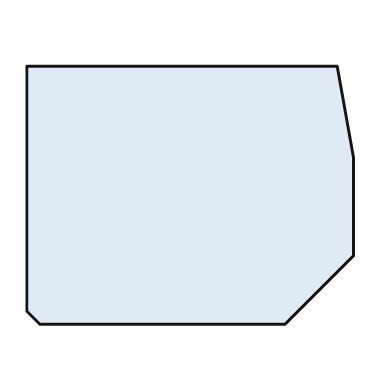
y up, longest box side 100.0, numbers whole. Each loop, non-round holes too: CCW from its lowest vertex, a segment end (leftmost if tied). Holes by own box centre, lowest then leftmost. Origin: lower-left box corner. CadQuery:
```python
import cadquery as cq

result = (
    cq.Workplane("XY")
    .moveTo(4.0, 0.0)
    .lineTo(79.0, 0.0)
    .lineTo(100.0, 21.0)
    .lineTo(100.0, 51.0)
    .lineTo(95.0, 79.0)
    .lineTo(0.0, 79.0)
    .lineTo(0.0, 4.0)
    .close()
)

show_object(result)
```